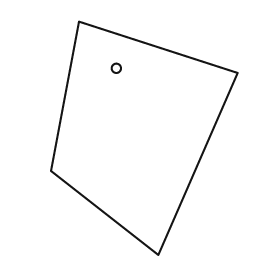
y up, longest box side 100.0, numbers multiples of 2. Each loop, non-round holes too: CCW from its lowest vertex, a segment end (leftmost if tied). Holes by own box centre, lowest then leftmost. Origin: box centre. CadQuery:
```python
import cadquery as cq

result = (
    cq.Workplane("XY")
    .moveTo(6.0, -50.0)
    .lineTo(40.0, 28.0)
    .lineTo(-28.0, 50.0)
    .lineTo(-40.0, -14.0)
    .close()
    .moveTo(-12.0, 30.0)
    .circle(2.0)
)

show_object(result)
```